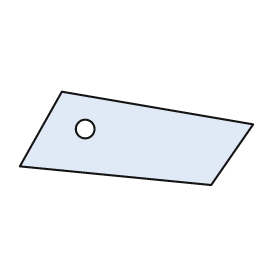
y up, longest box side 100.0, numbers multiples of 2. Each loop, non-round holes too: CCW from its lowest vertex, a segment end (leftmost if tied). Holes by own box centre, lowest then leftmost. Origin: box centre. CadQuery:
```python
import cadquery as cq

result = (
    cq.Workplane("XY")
    .moveTo(32.0, -20.0)
    .lineTo(50.0, 6.0)
    .lineTo(-32.0, 20.0)
    .lineTo(-50.0, -12.0)
    .close()
    .moveTo(-22.0, 4.0)
    .circle(4.0)
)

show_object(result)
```